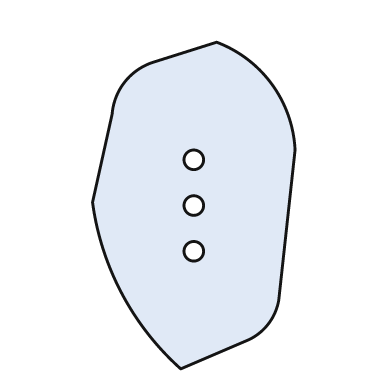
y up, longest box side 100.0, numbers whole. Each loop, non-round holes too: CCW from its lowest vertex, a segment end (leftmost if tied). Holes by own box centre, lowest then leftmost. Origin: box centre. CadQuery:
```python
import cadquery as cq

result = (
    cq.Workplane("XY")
    .moveTo(-4.0, -50.0)
    .lineTo(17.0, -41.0)
    .threePointArc((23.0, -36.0), (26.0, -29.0))
    .lineTo(31.0, 17.0)
    .threePointArc((24.0, 37.0), (7.0, 50.0))
    .lineTo(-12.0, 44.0)
    .threePointArc((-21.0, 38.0), (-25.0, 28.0))
    .lineTo(-31.0, 1.0)
    .threePointArc((-22.0, -27.0), (-4.0, -50.0))
    .close()
    .moveTo(0.0, -14.0)
    .circle(3.0)
    .moveTo(0.0, 0.0)
    .circle(3.0)
    .moveTo(0.0, 14.0)
    .circle(3.0)
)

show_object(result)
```